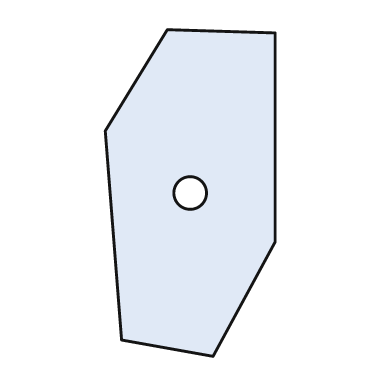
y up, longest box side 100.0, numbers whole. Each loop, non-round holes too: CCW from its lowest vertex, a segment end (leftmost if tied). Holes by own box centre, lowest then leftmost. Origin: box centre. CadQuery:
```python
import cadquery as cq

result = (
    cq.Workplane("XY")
    .moveTo(7.0, -50.0)
    .lineTo(26.0, -15.0)
    .lineTo(26.0, 49.0)
    .lineTo(-7.0, 50.0)
    .lineTo(-26.0, 19.0)
    .lineTo(-21.0, -45.0)
    .close()
    .moveTo(0.0, 0.0)
    .circle(5.0)
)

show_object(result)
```